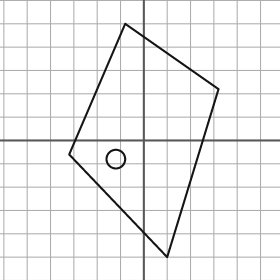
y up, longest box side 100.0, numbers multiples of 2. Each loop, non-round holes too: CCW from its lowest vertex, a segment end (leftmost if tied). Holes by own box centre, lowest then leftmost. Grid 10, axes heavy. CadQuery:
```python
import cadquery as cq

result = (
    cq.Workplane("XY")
    .moveTo(10.0, -50.0)
    .lineTo(32.0, 22.0)
    .lineTo(-8.0, 50.0)
    .lineTo(-32.0, -6.0)
    .close()
    .moveTo(-12.0, -8.0)
    .circle(4.0)
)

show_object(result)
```